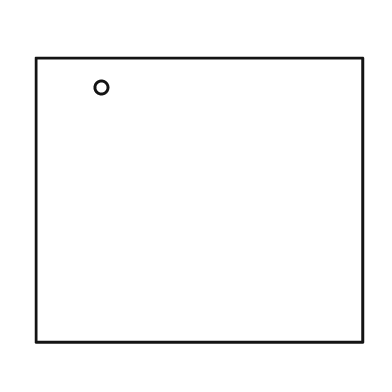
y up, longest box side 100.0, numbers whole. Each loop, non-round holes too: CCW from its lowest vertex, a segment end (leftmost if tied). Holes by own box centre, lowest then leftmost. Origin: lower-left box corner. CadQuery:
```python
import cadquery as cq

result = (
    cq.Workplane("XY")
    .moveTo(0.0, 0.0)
    .lineTo(100.0, 0.0)
    .lineTo(100.0, 87.0)
    .lineTo(0.0, 87.0)
    .close()
    .moveTo(20.0, 78.0)
    .circle(2.0)
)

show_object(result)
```